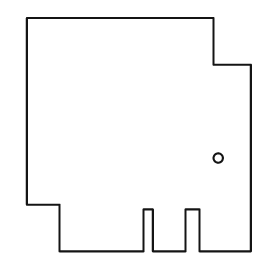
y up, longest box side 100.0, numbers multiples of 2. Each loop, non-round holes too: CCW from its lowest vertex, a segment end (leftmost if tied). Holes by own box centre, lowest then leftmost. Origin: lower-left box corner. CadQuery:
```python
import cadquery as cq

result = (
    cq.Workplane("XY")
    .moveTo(14.0, 0.0)
    .lineTo(50.0, 0.0)
    .lineTo(50.0, 18.0)
    .lineTo(54.0, 18.0)
    .lineTo(54.0, 0.0)
    .lineTo(68.0, 0.0)
    .lineTo(68.0, 18.0)
    .lineTo(74.0, 18.0)
    .lineTo(74.0, 0.0)
    .lineTo(96.0, 0.0)
    .lineTo(96.0, 80.0)
    .lineTo(80.0, 80.0)
    .lineTo(80.0, 100.0)
    .lineTo(0.0, 100.0)
    .lineTo(0.0, 20.0)
    .lineTo(14.0, 20.0)
    .close()
    .moveTo(82.0, 40.0)
    .circle(2.0)
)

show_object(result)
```